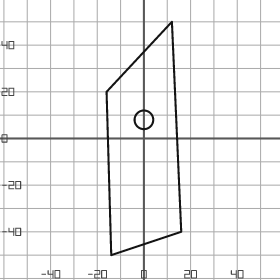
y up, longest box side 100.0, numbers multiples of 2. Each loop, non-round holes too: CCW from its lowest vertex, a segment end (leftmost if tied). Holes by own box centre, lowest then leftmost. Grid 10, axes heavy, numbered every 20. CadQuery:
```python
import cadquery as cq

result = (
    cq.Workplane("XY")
    .moveTo(-14.0, -50.0)
    .lineTo(16.0, -40.0)
    .lineTo(12.0, 50.0)
    .lineTo(-16.0, 20.0)
    .close()
    .moveTo(0.0, 8.0)
    .circle(4.0)
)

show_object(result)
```